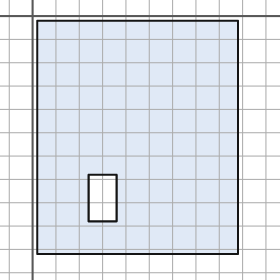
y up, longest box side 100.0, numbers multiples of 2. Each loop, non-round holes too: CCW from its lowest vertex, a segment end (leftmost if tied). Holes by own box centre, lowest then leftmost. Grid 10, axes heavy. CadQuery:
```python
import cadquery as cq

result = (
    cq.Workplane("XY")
    .moveTo(2.0, -102.0)
    .lineTo(88.0, -102.0)
    .lineTo(88.0, -2.0)
    .lineTo(2.0, -2.0)
    .close()
    .moveTo(24.0, -88.0)
    .lineTo(36.0, -88.0)
    .lineTo(36.0, -68.0)
    .lineTo(24.0, -68.0)
    .close()
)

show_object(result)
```